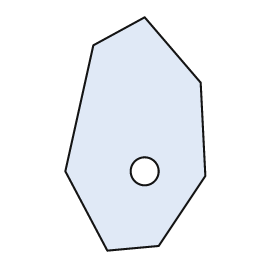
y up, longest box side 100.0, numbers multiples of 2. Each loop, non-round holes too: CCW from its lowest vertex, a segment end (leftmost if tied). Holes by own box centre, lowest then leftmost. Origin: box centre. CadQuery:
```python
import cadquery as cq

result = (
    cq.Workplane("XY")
    .moveTo(-12.0, -50.0)
    .lineTo(10.0, -48.0)
    .lineTo(30.0, -18.0)
    .lineTo(28.0, 22.0)
    .lineTo(4.0, 50.0)
    .lineTo(-18.0, 38.0)
    .lineTo(-30.0, -16.0)
    .close()
    .moveTo(4.0, -16.0)
    .circle(6.0)
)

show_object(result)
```